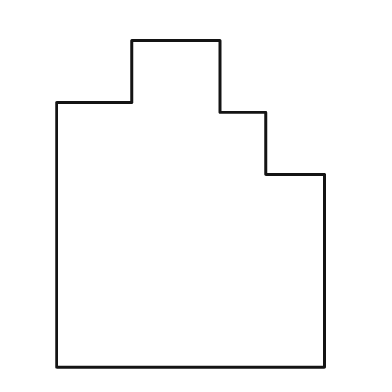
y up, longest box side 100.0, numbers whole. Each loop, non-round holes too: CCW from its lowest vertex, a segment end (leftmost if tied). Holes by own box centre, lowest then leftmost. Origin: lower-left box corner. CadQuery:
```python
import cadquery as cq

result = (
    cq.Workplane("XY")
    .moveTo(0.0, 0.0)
    .lineTo(82.0, 0.0)
    .lineTo(82.0, 59.0)
    .lineTo(64.0, 59.0)
    .lineTo(64.0, 78.0)
    .lineTo(50.0, 78.0)
    .lineTo(50.0, 100.0)
    .lineTo(23.0, 100.0)
    .lineTo(23.0, 81.0)
    .lineTo(0.0, 81.0)
    .close()
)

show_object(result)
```